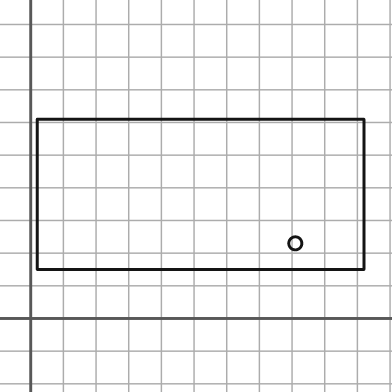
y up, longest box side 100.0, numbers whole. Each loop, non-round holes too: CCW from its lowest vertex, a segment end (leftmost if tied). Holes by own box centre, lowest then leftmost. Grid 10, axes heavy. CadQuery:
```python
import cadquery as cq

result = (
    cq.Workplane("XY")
    .moveTo(2.0, 15.0)
    .lineTo(102.0, 15.0)
    .lineTo(102.0, 61.0)
    .lineTo(2.0, 61.0)
    .close()
    .moveTo(81.0, 23.0)
    .circle(2.0)
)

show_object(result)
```